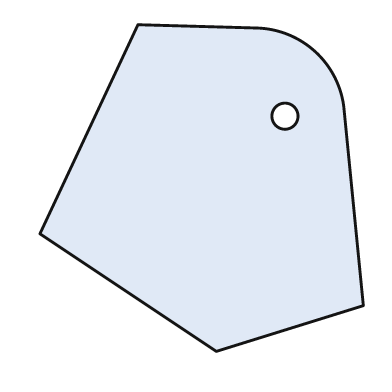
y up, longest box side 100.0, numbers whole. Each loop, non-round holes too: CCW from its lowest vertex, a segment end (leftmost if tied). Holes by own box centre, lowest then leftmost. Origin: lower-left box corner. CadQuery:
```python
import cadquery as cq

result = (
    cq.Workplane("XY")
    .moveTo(54.0, 0.0)
    .lineTo(99.0, 14.0)
    .lineTo(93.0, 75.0)
    .threePointArc((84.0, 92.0), (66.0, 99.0))
    .lineTo(30.0, 100.0)
    .lineTo(0.0, 36.0)
    .close()
    .moveTo(75.0, 72.0)
    .circle(4.0)
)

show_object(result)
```